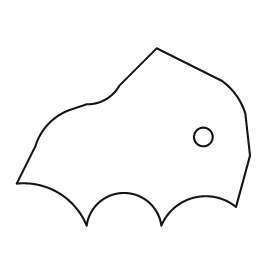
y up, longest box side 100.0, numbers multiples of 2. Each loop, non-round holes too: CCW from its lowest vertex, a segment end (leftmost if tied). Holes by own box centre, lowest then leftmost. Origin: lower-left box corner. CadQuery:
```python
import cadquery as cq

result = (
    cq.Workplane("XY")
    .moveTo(30.0, 0.0)
    .threePointArc((46.0, 14.0), (62.0, 0.0))
    .threePointArc((76.0, 12.0), (94.0, 8.0))
    .lineTo(100.0, 30.0)
    .lineTo(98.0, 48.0)
    .threePointArc((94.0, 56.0), (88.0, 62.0))
    .lineTo(60.0, 76.0)
    .lineTo(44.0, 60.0)
    .threePointArc((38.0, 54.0), (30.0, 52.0))
    .lineTo(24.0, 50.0)
    .threePointArc((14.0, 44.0), (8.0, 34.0))
    .lineTo(0.0, 18.0)
    .threePointArc((18.0, 14.0), (30.0, 0.0))
    .close()
    .moveTo(80.0, 38.0)
    .circle(4.0)
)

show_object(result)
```